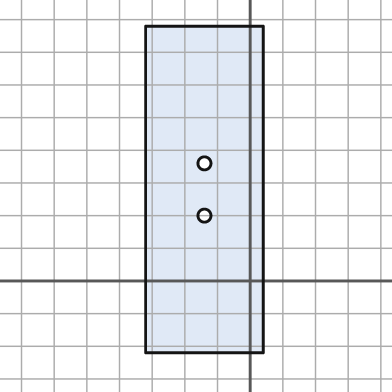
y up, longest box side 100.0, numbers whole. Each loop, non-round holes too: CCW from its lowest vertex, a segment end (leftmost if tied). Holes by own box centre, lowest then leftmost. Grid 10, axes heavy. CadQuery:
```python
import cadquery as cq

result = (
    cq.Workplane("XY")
    .moveTo(-32.0, -22.0)
    .lineTo(4.0, -22.0)
    .lineTo(4.0, 78.0)
    .lineTo(-32.0, 78.0)
    .close()
    .moveTo(-14.0, 20.0)
    .circle(2.0)
    .moveTo(-14.0, 36.0)
    .circle(2.0)
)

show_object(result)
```